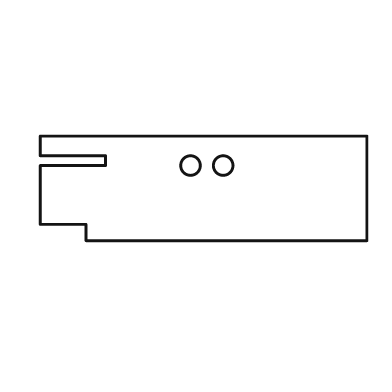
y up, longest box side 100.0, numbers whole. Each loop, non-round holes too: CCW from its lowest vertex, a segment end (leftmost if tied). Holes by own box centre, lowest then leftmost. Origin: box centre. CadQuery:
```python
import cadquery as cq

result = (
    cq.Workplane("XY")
    .moveTo(-36.0, -16.0)
    .lineTo(50.0, -16.0)
    .lineTo(50.0, 16.0)
    .lineTo(-50.0, 16.0)
    .lineTo(-50.0, 10.0)
    .lineTo(-30.0, 10.0)
    .lineTo(-30.0, 7.0)
    .lineTo(-50.0, 7.0)
    .lineTo(-50.0, -11.0)
    .lineTo(-36.0, -11.0)
    .close()
    .moveTo(-4.0, 7.0)
    .circle(3.0)
    .moveTo(6.0, 7.0)
    .circle(3.0)
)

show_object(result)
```